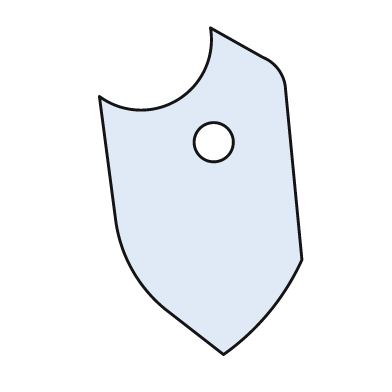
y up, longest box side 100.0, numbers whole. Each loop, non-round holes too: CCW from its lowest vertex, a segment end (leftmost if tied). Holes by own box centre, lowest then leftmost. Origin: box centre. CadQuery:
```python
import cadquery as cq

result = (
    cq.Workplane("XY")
    .moveTo(7.0, -50.0)
    .threePointArc((21.0, -37.0), (31.0, -21.0))
    .lineTo(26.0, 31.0)
    .threePointArc((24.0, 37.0), (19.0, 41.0))
    .lineTo(3.0, 50.0)
    .threePointArc((-7.0, 28.0), (-31.0, 29.0))
    .lineTo(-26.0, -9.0)
    .threePointArc((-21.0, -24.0), (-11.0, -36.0))
    .close()
    .moveTo(4.0, 15.0)
    .circle(6.0)
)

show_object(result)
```